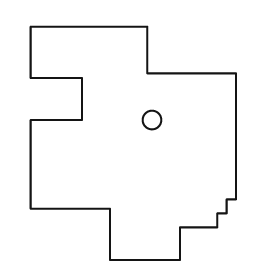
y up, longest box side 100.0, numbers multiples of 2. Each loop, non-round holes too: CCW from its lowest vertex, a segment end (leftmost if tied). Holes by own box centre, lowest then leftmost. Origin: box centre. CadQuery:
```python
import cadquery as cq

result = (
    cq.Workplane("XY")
    .moveTo(-10.0, -50.0)
    .lineTo(20.0, -50.0)
    .lineTo(20.0, -36.0)
    .lineTo(36.0, -36.0)
    .lineTo(36.0, -30.0)
    .lineTo(40.0, -30.0)
    .lineTo(40.0, -24.0)
    .lineTo(44.0, -24.0)
    .lineTo(44.0, 30.0)
    .lineTo(6.0, 30.0)
    .lineTo(6.0, 50.0)
    .lineTo(-44.0, 50.0)
    .lineTo(-44.0, 28.0)
    .lineTo(-22.0, 28.0)
    .lineTo(-22.0, 10.0)
    .lineTo(-44.0, 10.0)
    .lineTo(-44.0, -28.0)
    .lineTo(-10.0, -28.0)
    .close()
    .moveTo(8.0, 10.0)
    .circle(4.0)
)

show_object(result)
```